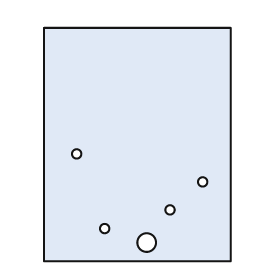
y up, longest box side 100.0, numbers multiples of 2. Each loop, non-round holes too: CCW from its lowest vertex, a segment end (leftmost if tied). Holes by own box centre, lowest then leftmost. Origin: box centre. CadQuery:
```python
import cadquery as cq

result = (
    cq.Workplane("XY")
    .moveTo(-40.0, -50.0)
    .lineTo(40.0, -50.0)
    .lineTo(40.0, 50.0)
    .lineTo(-40.0, 50.0)
    .close()
    .moveTo(4.0, -42.0)
    .circle(4.0)
    .moveTo(-14.0, -36.0)
    .circle(2.0)
    .moveTo(14.0, -28.0)
    .circle(2.0)
    .moveTo(28.0, -16.0)
    .circle(2.0)
    .moveTo(-26.0, -4.0)
    .circle(2.0)
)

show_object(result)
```